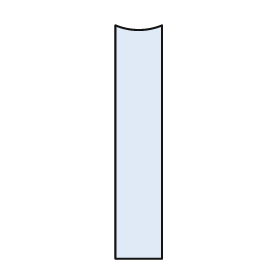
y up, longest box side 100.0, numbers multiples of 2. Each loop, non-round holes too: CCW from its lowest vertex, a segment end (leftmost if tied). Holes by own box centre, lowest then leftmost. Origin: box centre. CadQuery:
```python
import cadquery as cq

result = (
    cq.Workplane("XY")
    .moveTo(-10.0, -50.0)
    .lineTo(10.0, -50.0)
    .lineTo(10.0, 50.0)
    .threePointArc((0.0, 48.0), (-10.0, 50.0))
    .close()
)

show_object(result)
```